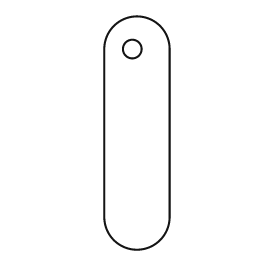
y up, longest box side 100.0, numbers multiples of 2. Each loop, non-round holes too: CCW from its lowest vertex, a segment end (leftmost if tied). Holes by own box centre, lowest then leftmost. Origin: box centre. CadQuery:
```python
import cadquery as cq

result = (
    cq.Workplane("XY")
    .moveTo(-14.0, -36.0)
    .threePointArc((0.0, -50.0), (14.0, -36.0))
    .lineTo(14.0, 36.0)
    .threePointArc((0.0, 50.0), (-14.0, 36.0))
    .close()
    .moveTo(-2.0, 36.0)
    .circle(4.0)
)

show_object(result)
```